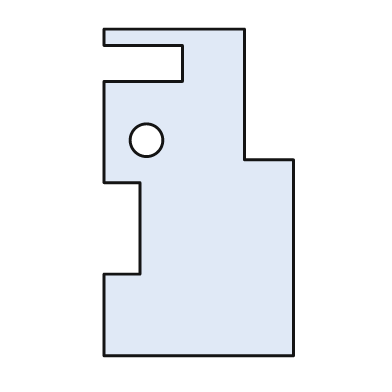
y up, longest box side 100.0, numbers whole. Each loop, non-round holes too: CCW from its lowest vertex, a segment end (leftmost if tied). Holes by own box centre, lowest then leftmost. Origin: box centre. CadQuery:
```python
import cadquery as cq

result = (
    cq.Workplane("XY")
    .moveTo(-29.0, -50.0)
    .lineTo(29.0, -50.0)
    .lineTo(29.0, 10.0)
    .lineTo(14.0, 10.0)
    .lineTo(14.0, 50.0)
    .lineTo(-29.0, 50.0)
    .lineTo(-29.0, 45.0)
    .lineTo(-5.0, 45.0)
    .lineTo(-5.0, 34.0)
    .lineTo(-29.0, 34.0)
    .lineTo(-29.0, 3.0)
    .lineTo(-18.0, 3.0)
    .lineTo(-18.0, -25.0)
    .lineTo(-29.0, -25.0)
    .close()
    .moveTo(-16.0, 16.0)
    .circle(5.0)
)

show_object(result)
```